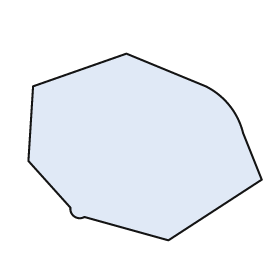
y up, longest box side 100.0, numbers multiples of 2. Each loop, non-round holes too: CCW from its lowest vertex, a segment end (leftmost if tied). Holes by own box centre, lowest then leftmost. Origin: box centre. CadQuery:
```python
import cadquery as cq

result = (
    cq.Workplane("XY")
    .moveTo(10.0, -40.0)
    .lineTo(50.0, -14.0)
    .lineTo(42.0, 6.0)
    .threePointArc((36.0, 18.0), (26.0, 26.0))
    .lineTo(-8.0, 40.0)
    .lineTo(-48.0, 26.0)
    .lineTo(-50.0, -6.0)
    .lineTo(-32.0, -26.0)
    .threePointArc((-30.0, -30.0), (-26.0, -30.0))
    .close()
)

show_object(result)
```